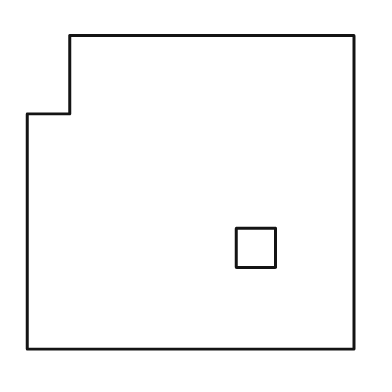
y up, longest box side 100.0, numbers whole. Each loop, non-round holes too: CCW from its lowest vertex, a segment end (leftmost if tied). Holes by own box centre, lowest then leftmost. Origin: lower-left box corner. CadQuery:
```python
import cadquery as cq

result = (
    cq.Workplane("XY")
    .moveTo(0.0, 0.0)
    .lineTo(100.0, 0.0)
    .lineTo(100.0, 96.0)
    .lineTo(13.0, 96.0)
    .lineTo(13.0, 72.0)
    .lineTo(0.0, 72.0)
    .close()
    .moveTo(64.0, 25.0)
    .lineTo(76.0, 25.0)
    .lineTo(76.0, 37.0)
    .lineTo(64.0, 37.0)
    .close()
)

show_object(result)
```